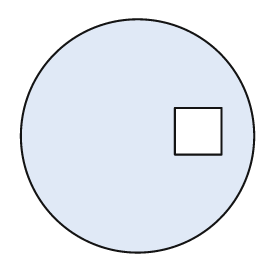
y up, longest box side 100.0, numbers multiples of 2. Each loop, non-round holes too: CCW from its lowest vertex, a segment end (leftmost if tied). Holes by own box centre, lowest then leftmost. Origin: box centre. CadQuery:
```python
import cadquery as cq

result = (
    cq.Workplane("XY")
    .moveTo(0.0, 0.0)
    .circle(50.0)
    .moveTo(16.0, -8.0)
    .lineTo(36.0, -8.0)
    .lineTo(36.0, 12.0)
    .lineTo(16.0, 12.0)
    .close()
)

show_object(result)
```